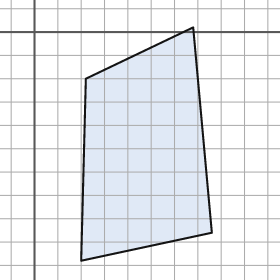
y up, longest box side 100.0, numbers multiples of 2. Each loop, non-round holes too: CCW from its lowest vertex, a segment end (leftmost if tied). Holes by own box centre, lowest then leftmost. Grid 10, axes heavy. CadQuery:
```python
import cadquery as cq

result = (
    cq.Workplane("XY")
    .moveTo(20.0, -98.0)
    .lineTo(76.0, -86.0)
    .lineTo(68.0, 2.0)
    .lineTo(22.0, -20.0)
    .close()
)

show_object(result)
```